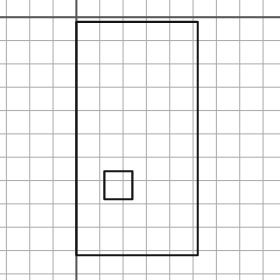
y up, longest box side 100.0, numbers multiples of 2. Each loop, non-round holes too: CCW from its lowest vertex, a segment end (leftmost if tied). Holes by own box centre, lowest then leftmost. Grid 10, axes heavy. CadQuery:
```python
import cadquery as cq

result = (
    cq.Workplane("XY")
    .moveTo(0.0, -102.0)
    .lineTo(52.0, -102.0)
    .lineTo(52.0, -2.0)
    .lineTo(0.0, -2.0)
    .close()
    .moveTo(12.0, -78.0)
    .lineTo(24.0, -78.0)
    .lineTo(24.0, -66.0)
    .lineTo(12.0, -66.0)
    .close()
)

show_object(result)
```